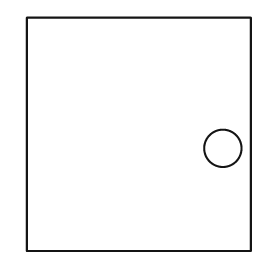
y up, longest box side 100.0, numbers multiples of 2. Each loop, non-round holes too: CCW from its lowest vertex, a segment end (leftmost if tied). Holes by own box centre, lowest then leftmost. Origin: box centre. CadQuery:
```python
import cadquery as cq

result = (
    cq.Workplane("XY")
    .moveTo(-48.0, -50.0)
    .lineTo(48.0, -50.0)
    .lineTo(48.0, 50.0)
    .lineTo(-48.0, 50.0)
    .close()
    .moveTo(36.0, -6.0)
    .circle(8.0)
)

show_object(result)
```